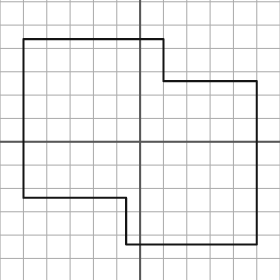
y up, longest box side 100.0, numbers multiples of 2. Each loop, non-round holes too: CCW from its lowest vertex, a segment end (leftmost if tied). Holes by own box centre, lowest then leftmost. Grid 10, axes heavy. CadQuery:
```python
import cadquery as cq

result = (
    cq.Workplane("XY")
    .moveTo(-6.0, -44.0)
    .lineTo(50.0, -44.0)
    .lineTo(50.0, 26.0)
    .lineTo(10.0, 26.0)
    .lineTo(10.0, 44.0)
    .lineTo(-50.0, 44.0)
    .lineTo(-50.0, -24.0)
    .lineTo(-6.0, -24.0)
    .close()
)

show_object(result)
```